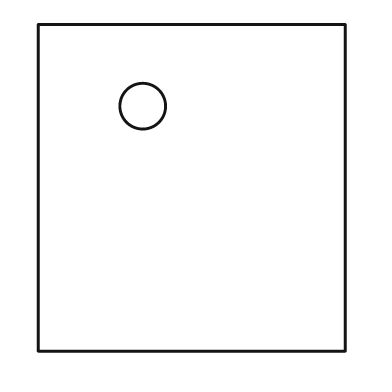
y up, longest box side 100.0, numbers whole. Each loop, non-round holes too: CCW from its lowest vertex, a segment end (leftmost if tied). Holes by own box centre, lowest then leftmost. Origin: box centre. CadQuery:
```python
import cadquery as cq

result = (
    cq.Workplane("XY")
    .moveTo(-47.0, -50.0)
    .lineTo(47.0, -50.0)
    .lineTo(47.0, 50.0)
    .lineTo(-47.0, 50.0)
    .close()
    .moveTo(-15.0, 25.0)
    .circle(7.0)
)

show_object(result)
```